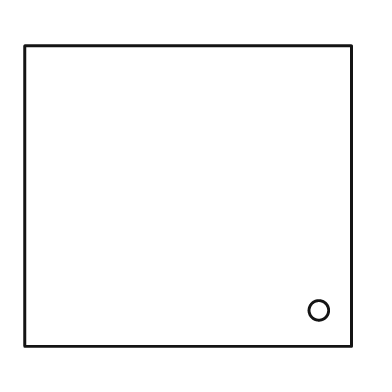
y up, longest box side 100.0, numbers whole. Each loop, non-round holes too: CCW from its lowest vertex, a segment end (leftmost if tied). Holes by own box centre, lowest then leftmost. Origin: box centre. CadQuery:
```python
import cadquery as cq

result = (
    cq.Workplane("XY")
    .moveTo(-50.0, -46.0)
    .lineTo(50.0, -46.0)
    .lineTo(50.0, 46.0)
    .lineTo(-50.0, 46.0)
    .close()
    .moveTo(40.0, -35.0)
    .circle(3.0)
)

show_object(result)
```